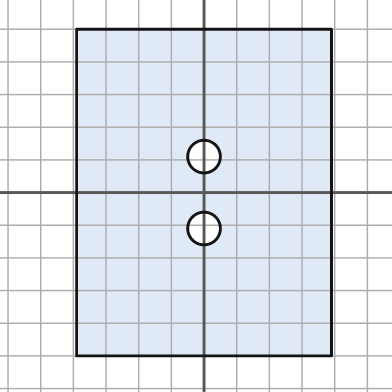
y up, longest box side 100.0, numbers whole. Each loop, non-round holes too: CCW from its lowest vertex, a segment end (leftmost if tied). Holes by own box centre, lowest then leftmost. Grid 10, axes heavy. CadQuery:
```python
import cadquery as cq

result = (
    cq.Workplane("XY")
    .moveTo(-39.0, -50.0)
    .lineTo(39.0, -50.0)
    .lineTo(39.0, 50.0)
    .lineTo(-39.0, 50.0)
    .close()
    .moveTo(0.0, -11.0)
    .circle(5.0)
    .moveTo(0.0, 11.0)
    .circle(5.0)
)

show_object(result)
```